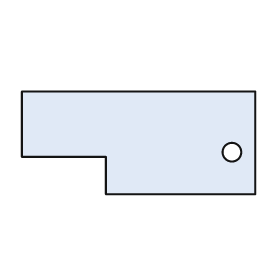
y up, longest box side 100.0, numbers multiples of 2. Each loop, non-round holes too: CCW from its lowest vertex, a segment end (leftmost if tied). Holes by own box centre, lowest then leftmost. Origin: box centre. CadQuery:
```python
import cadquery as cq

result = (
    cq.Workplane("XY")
    .moveTo(-14.0, -22.0)
    .lineTo(50.0, -22.0)
    .lineTo(50.0, 22.0)
    .lineTo(-50.0, 22.0)
    .lineTo(-50.0, -6.0)
    .lineTo(-14.0, -6.0)
    .close()
    .moveTo(40.0, -4.0)
    .circle(4.0)
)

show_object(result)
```